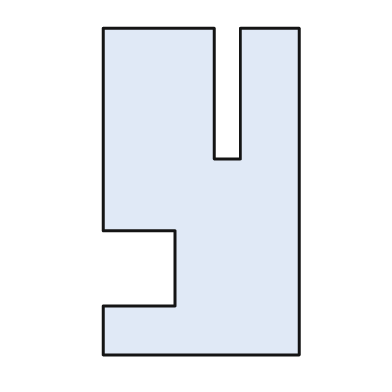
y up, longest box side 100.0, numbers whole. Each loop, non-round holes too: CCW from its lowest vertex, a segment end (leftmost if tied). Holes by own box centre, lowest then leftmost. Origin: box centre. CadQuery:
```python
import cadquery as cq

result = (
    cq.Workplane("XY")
    .moveTo(-30.0, -50.0)
    .lineTo(30.0, -50.0)
    .lineTo(30.0, 50.0)
    .lineTo(12.0, 50.0)
    .lineTo(12.0, 10.0)
    .lineTo(4.0, 10.0)
    .lineTo(4.0, 50.0)
    .lineTo(-30.0, 50.0)
    .lineTo(-30.0, -12.0)
    .lineTo(-8.0, -12.0)
    .lineTo(-8.0, -35.0)
    .lineTo(-30.0, -35.0)
    .close()
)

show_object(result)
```